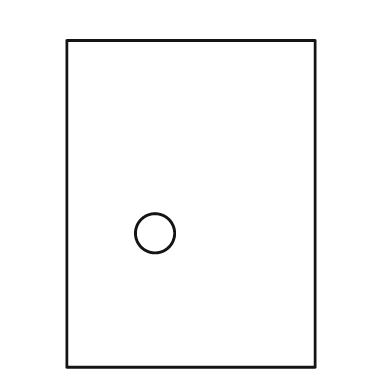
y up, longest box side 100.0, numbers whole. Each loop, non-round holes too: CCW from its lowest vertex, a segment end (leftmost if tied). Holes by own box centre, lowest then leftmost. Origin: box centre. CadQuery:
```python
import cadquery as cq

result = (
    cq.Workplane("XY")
    .moveTo(-38.0, -50.0)
    .lineTo(38.0, -50.0)
    .lineTo(38.0, 50.0)
    .lineTo(-38.0, 50.0)
    .close()
    .moveTo(-11.0, -9.0)
    .circle(6.0)
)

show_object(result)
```